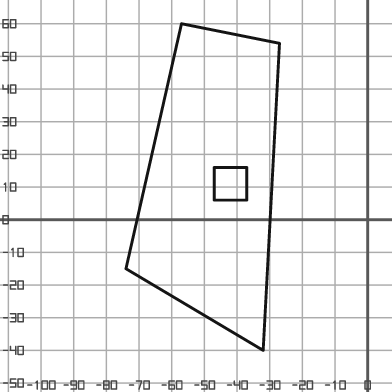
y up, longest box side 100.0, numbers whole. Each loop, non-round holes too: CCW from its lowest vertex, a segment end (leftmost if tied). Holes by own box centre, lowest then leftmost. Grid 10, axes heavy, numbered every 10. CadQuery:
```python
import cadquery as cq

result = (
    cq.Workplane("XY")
    .moveTo(-32.0, -40.0)
    .lineTo(-27.0, 54.0)
    .lineTo(-57.0, 60.0)
    .lineTo(-74.0, -15.0)
    .close()
    .moveTo(-47.0, 6.0)
    .lineTo(-37.0, 6.0)
    .lineTo(-37.0, 16.0)
    .lineTo(-47.0, 16.0)
    .close()
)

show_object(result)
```